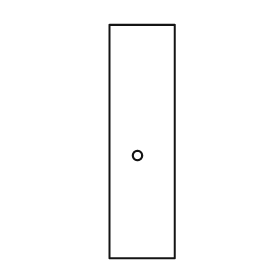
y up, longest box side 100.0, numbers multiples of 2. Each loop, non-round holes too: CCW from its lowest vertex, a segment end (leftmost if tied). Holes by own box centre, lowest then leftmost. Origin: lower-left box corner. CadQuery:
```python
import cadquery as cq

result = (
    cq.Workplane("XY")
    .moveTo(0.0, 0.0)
    .lineTo(28.0, 0.0)
    .lineTo(28.0, 100.0)
    .lineTo(0.0, 100.0)
    .close()
    .moveTo(12.0, 44.0)
    .circle(2.0)
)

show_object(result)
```